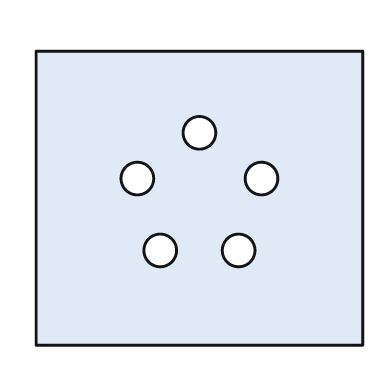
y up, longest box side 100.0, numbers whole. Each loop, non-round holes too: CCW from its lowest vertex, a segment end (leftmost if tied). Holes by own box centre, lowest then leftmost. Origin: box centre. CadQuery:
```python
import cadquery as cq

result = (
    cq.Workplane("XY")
    .moveTo(-50.0, -45.0)
    .lineTo(50.0, -45.0)
    .lineTo(50.0, 45.0)
    .lineTo(-50.0, 45.0)
    .close()
    .moveTo(-12.0, -16.0)
    .circle(5.0)
    .moveTo(12.0, -16.0)
    .circle(5.0)
    .moveTo(-19.0, 6.0)
    .circle(5.0)
    .moveTo(19.0, 6.0)
    .circle(5.0)
    .moveTo(0.0, 20.0)
    .circle(5.0)
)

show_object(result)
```